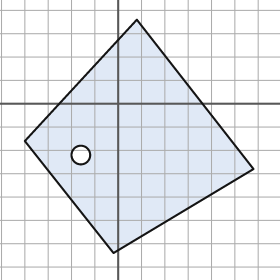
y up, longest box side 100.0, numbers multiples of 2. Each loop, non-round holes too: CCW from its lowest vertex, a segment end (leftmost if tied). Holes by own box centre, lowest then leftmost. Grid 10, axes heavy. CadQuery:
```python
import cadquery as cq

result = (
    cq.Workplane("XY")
    .moveTo(-2.0, -64.0)
    .lineTo(58.0, -28.0)
    .lineTo(8.0, 36.0)
    .lineTo(-40.0, -16.0)
    .close()
    .moveTo(-16.0, -22.0)
    .circle(4.0)
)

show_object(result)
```